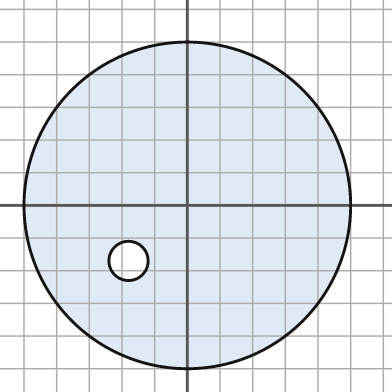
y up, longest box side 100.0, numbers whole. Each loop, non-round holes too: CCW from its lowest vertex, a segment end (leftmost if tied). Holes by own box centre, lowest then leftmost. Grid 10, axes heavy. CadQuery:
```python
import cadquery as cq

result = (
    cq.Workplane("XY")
    .moveTo(0.0, 0.0)
    .circle(50.0)
    .moveTo(-18.0, -17.0)
    .circle(6.0)
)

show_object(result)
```